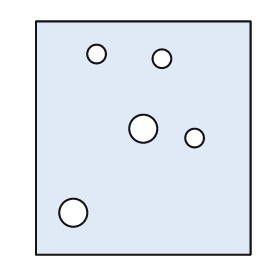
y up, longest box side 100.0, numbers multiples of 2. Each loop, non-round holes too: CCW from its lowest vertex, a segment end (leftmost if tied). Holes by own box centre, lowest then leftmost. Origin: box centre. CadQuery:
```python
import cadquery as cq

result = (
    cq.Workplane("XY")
    .moveTo(-46.0, -50.0)
    .lineTo(46.0, -50.0)
    .lineTo(46.0, 50.0)
    .lineTo(-46.0, 50.0)
    .close()
    .moveTo(-30.0, -32.0)
    .circle(6.0)
    .moveTo(22.0, 0.0)
    .circle(4.0)
    .moveTo(0.0, 4.0)
    .circle(6.0)
    .moveTo(8.0, 34.0)
    .circle(4.0)
    .moveTo(-20.0, 36.0)
    .circle(4.0)
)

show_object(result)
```